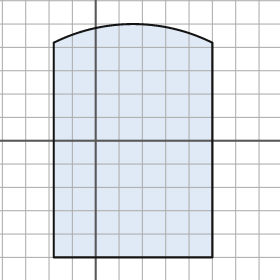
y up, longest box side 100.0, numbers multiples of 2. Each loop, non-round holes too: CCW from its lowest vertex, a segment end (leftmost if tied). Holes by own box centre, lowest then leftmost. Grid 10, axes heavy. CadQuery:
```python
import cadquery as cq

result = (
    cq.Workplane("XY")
    .moveTo(-18.0, -50.0)
    .lineTo(50.0, -50.0)
    .lineTo(50.0, 42.0)
    .threePointArc((16.0, 50.0), (-18.0, 42.0))
    .close()
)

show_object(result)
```